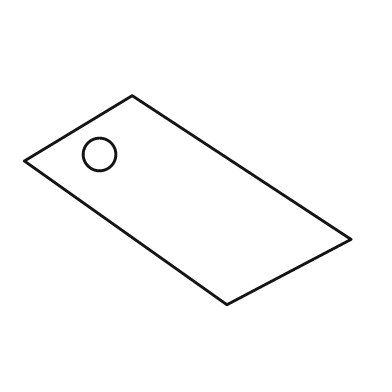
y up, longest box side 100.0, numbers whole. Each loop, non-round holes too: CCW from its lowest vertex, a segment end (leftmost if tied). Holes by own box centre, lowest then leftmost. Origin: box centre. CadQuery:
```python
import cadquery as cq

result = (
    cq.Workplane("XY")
    .moveTo(12.0, -32.0)
    .lineTo(50.0, -12.0)
    .lineTo(-17.0, 32.0)
    .lineTo(-50.0, 12.0)
    .close()
    .moveTo(-27.0, 14.0)
    .circle(5.0)
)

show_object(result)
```